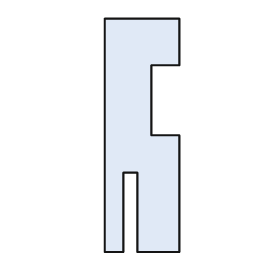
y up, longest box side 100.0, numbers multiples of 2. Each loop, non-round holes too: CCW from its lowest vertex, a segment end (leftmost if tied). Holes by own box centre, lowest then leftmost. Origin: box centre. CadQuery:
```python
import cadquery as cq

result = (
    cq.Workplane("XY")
    .moveTo(-16.0, -50.0)
    .lineTo(-8.0, -50.0)
    .lineTo(-8.0, -16.0)
    .lineTo(-2.0, -16.0)
    .lineTo(-2.0, -50.0)
    .lineTo(16.0, -50.0)
    .lineTo(16.0, 0.0)
    .lineTo(4.0, 0.0)
    .lineTo(4.0, 30.0)
    .lineTo(16.0, 30.0)
    .lineTo(16.0, 50.0)
    .lineTo(-16.0, 50.0)
    .close()
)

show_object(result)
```